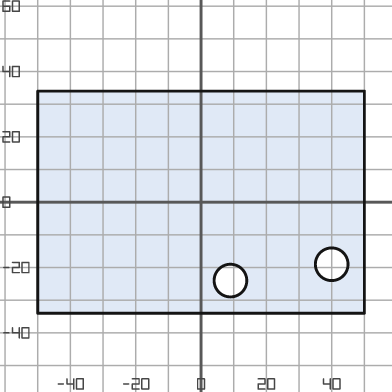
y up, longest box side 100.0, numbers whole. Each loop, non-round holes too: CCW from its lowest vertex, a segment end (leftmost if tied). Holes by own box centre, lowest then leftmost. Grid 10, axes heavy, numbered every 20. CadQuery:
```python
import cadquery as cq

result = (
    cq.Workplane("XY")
    .moveTo(-50.0, -34.0)
    .lineTo(50.0, -34.0)
    .lineTo(50.0, 34.0)
    .lineTo(-50.0, 34.0)
    .close()
    .moveTo(9.0, -24.0)
    .circle(5.0)
    .moveTo(40.0, -19.0)
    .circle(5.0)
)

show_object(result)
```